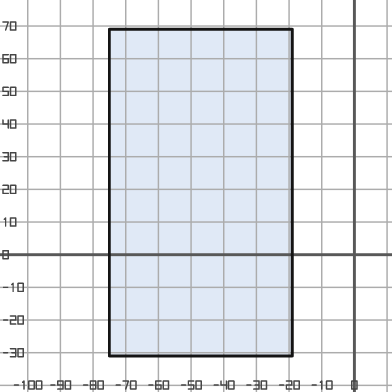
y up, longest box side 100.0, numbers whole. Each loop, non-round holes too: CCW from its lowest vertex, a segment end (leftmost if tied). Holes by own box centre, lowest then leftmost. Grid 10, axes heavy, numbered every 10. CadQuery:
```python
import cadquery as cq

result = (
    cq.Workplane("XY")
    .moveTo(-75.0, -31.0)
    .lineTo(-19.0, -31.0)
    .lineTo(-19.0, 69.0)
    .lineTo(-75.0, 69.0)
    .close()
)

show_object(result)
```